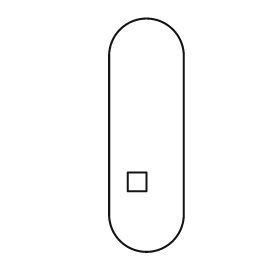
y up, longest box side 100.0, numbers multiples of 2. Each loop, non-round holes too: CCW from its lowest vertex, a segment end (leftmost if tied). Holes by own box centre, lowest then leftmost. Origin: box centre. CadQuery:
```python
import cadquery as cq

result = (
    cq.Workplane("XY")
    .moveTo(-16.0, -34.0)
    .threePointArc((0.0, -50.0), (16.0, -34.0))
    .lineTo(16.0, 34.0)
    .threePointArc((0.0, 50.0), (-16.0, 34.0))
    .close()
    .moveTo(-8.0, -24.0)
    .lineTo(0.0, -24.0)
    .lineTo(0.0, -16.0)
    .lineTo(-8.0, -16.0)
    .close()
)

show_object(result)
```